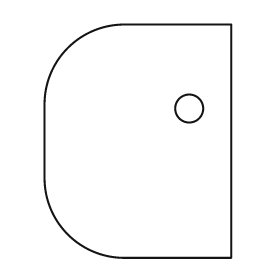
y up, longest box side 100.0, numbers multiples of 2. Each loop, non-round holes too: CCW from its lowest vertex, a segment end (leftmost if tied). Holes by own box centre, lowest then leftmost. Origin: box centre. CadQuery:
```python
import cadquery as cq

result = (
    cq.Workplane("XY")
    .moveTo(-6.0, -50.0)
    .lineTo(40.0, -50.0)
    .lineTo(40.0, 50.0)
    .lineTo(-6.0, 50.0)
    .threePointArc((-30.0, 40.0), (-40.0, 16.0))
    .lineTo(-40.0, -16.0)
    .threePointArc((-30.0, -40.0), (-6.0, -50.0))
    .close()
    .moveTo(22.0, 14.0)
    .circle(6.0)
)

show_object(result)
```